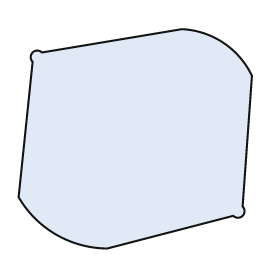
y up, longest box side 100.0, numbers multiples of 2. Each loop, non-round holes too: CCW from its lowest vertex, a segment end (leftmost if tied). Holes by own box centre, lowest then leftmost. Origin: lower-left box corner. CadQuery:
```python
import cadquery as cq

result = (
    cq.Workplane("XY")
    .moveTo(38.0, 0.0)
    .lineTo(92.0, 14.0)
    .threePointArc((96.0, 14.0), (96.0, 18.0))
    .lineTo(100.0, 74.0)
    .threePointArc((88.0, 88.0), (70.0, 94.0))
    .lineTo(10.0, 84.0)
    .threePointArc((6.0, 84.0), (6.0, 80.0))
    .lineTo(0.0, 22.0)
    .threePointArc((16.0, 6.0), (38.0, 0.0))
    .close()
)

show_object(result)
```